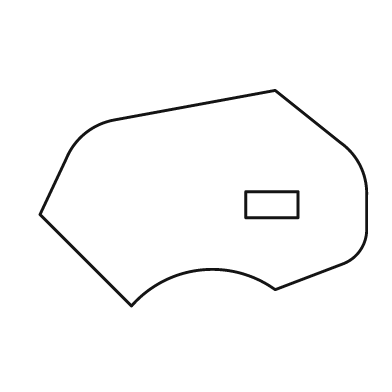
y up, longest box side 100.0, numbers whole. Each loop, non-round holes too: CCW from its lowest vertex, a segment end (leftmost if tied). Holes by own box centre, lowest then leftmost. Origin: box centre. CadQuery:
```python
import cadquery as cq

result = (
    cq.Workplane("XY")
    .moveTo(-22.0, -33.0)
    .threePointArc((-1.0, -22.0), (22.0, -28.0))
    .lineTo(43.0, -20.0)
    .threePointArc((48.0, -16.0), (50.0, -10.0))
    .lineTo(50.0, 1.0)
    .threePointArc((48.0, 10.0), (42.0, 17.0))
    .lineTo(22.0, 33.0)
    .lineTo(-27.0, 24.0)
    .threePointArc((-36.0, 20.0), (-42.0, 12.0))
    .lineTo(-50.0, -5.0)
    .close()
    .moveTo(13.0, -6.0)
    .lineTo(29.0, -6.0)
    .lineTo(29.0, 2.0)
    .lineTo(13.0, 2.0)
    .close()
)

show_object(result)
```